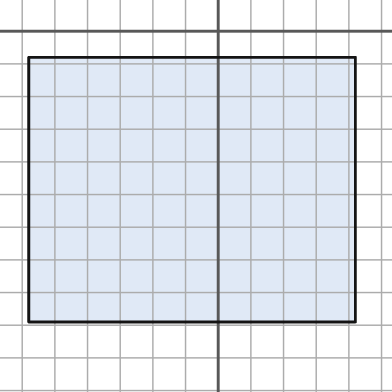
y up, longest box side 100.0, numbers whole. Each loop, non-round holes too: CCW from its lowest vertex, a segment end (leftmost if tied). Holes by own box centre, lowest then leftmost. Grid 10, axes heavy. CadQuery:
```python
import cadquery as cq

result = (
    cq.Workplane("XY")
    .moveTo(-58.0, -89.0)
    .lineTo(42.0, -89.0)
    .lineTo(42.0, -8.0)
    .lineTo(-58.0, -8.0)
    .close()
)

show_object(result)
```